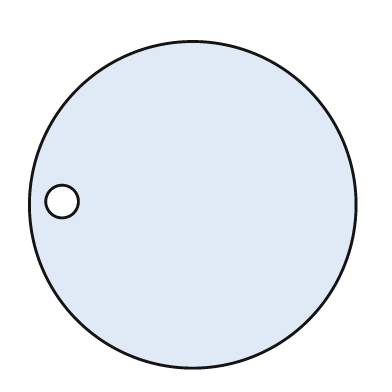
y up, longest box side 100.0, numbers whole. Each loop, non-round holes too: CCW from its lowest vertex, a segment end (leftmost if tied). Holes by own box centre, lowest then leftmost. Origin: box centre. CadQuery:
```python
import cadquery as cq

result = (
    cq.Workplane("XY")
    .moveTo(0.0, 0.0)
    .circle(50.0)
    .moveTo(-40.0, 1.0)
    .circle(5.0)
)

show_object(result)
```